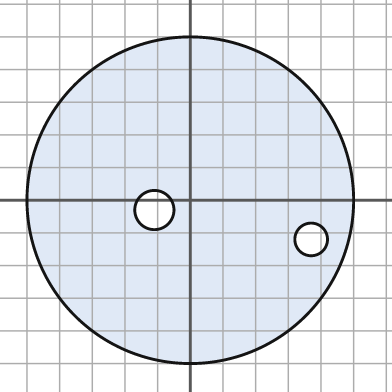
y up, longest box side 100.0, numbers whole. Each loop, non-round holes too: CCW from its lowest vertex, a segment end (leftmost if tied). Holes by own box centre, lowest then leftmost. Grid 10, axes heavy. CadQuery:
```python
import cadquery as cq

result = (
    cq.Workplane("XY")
    .moveTo(0.0, 0.0)
    .circle(50.0)
    .moveTo(37.0, -12.0)
    .circle(5.0)
    .moveTo(-11.0, -3.0)
    .circle(6.0)
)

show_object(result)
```